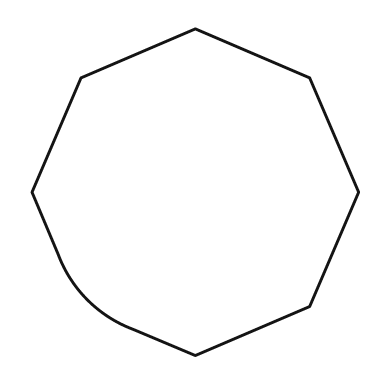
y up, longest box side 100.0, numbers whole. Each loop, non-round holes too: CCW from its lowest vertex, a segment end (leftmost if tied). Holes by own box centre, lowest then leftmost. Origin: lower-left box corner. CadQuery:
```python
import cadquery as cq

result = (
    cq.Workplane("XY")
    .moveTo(50.0, 0.0)
    .lineTo(85.0, 15.0)
    .lineTo(100.0, 50.0)
    .lineTo(85.0, 85.0)
    .lineTo(50.0, 100.0)
    .lineTo(15.0, 85.0)
    .lineTo(0.0, 50.0)
    .lineTo(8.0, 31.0)
    .threePointArc((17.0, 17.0), (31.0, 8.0))
    .close()
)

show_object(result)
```